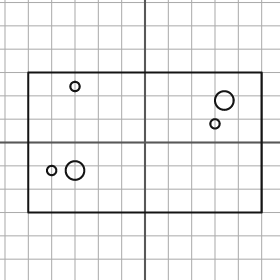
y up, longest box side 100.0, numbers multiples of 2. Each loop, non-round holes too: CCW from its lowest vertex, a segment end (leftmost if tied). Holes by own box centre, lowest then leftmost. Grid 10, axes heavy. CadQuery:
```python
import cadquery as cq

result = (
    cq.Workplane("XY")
    .moveTo(-50.0, -30.0)
    .lineTo(50.0, -30.0)
    .lineTo(50.0, 30.0)
    .lineTo(-50.0, 30.0)
    .close()
    .moveTo(-40.0, -12.0)
    .circle(2.0)
    .moveTo(-30.0, -12.0)
    .circle(4.0)
    .moveTo(30.0, 8.0)
    .circle(2.0)
    .moveTo(34.0, 18.0)
    .circle(4.0)
    .moveTo(-30.0, 24.0)
    .circle(2.0)
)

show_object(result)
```